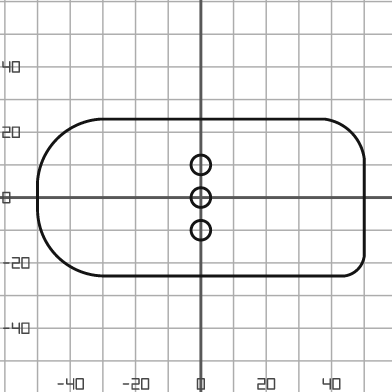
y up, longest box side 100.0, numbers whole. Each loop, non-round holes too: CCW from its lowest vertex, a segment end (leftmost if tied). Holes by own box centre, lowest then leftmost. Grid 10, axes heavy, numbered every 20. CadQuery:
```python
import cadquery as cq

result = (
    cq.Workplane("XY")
    .moveTo(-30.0, -24.0)
    .lineTo(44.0, -24.0)
    .threePointArc((48.0, -22.0), (50.0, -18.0))
    .lineTo(50.0, 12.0)
    .threePointArc((46.0, 20.0), (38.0, 24.0))
    .lineTo(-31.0, 24.0)
    .threePointArc((-44.0, 18.0), (-50.0, 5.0))
    .lineTo(-50.0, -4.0)
    .threePointArc((-44.0, -18.0), (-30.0, -24.0))
    .close()
    .moveTo(0.0, -10.0)
    .circle(3.0)
    .moveTo(0.0, 0.0)
    .circle(3.0)
    .moveTo(0.0, 10.0)
    .circle(3.0)
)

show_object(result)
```